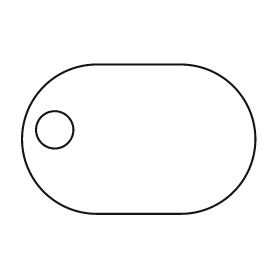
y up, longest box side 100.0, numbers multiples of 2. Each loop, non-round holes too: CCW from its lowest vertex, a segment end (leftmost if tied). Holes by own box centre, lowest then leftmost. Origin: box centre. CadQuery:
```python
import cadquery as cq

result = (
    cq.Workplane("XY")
    .moveTo(-18.0, -32.0)
    .lineTo(18.0, -32.0)
    .threePointArc((50.0, 0.0), (18.0, 32.0))
    .lineTo(-18.0, 32.0)
    .threePointArc((-50.0, 0.0), (-18.0, -32.0))
    .close()
    .moveTo(-36.0, 4.0)
    .circle(8.0)
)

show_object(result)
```